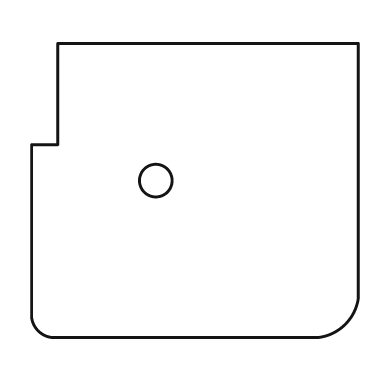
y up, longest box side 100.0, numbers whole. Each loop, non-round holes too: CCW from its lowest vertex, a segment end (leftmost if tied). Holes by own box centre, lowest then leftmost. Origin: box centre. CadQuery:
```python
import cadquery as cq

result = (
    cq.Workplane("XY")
    .moveTo(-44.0, -45.0)
    .lineTo(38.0, -45.0)
    .threePointArc((46.0, -41.0), (50.0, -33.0))
    .lineTo(50.0, 45.0)
    .lineTo(-42.0, 45.0)
    .lineTo(-42.0, 14.0)
    .lineTo(-50.0, 14.0)
    .lineTo(-50.0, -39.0)
    .threePointArc((-48.0, -43.0), (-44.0, -45.0))
    .close()
    .moveTo(-12.0, 3.0)
    .circle(5.0)
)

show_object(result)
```